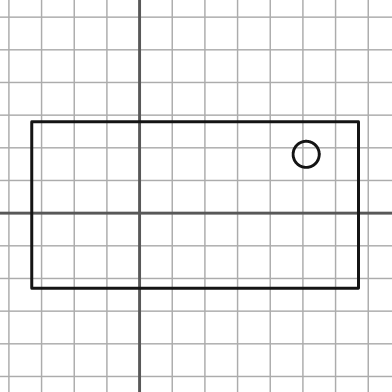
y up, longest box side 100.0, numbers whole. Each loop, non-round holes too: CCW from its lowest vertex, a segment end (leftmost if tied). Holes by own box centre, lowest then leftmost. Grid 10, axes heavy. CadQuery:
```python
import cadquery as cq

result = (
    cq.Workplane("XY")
    .moveTo(-33.0, -23.0)
    .lineTo(67.0, -23.0)
    .lineTo(67.0, 28.0)
    .lineTo(-33.0, 28.0)
    .close()
    .moveTo(51.0, 18.0)
    .circle(4.0)
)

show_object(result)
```